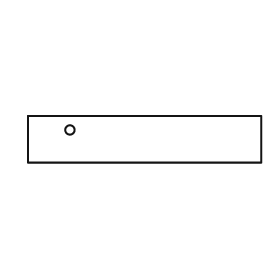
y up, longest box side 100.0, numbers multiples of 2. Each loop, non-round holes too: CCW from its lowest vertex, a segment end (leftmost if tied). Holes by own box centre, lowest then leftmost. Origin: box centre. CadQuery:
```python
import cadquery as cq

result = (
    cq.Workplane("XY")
    .moveTo(-50.0, -10.0)
    .lineTo(50.0, -10.0)
    .lineTo(50.0, 10.0)
    .lineTo(-50.0, 10.0)
    .close()
    .moveTo(-32.0, 4.0)
    .circle(2.0)
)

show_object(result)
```